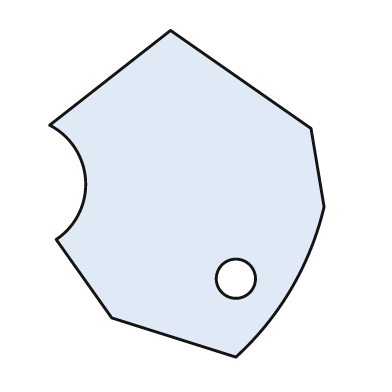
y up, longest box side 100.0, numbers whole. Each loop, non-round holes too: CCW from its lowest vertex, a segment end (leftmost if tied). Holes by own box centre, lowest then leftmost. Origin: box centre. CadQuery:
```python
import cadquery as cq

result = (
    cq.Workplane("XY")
    .moveTo(15.0, -50.0)
    .threePointArc((32.0, -29.0), (42.0, -4.0))
    .lineTo(38.0, 20.0)
    .lineTo(-5.0, 50.0)
    .lineTo(-42.0, 21.0)
    .threePointArc((-31.0, 4.0), (-40.0, -14.0))
    .lineTo(-23.0, -38.0)
    .close()
    .moveTo(15.0, -26.0)
    .circle(6.0)
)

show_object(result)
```